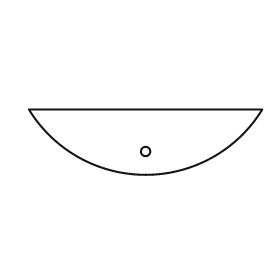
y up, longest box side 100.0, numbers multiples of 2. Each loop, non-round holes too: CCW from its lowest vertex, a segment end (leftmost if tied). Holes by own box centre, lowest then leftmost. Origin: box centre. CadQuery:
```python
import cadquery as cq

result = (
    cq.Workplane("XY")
    .moveTo(-50.0, 14.0)
    .threePointArc((0.0, -14.0), (50.0, 14.0))
    .close()
    .moveTo(0.0, -4.0)
    .circle(2.0)
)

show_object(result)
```